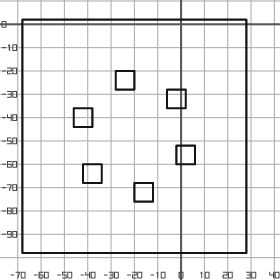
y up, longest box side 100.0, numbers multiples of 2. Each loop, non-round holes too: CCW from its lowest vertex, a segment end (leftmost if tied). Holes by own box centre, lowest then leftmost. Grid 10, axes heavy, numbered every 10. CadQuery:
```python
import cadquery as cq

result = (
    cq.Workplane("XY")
    .moveTo(-68.0, -98.0)
    .lineTo(28.0, -98.0)
    .lineTo(28.0, 2.0)
    .lineTo(-68.0, 2.0)
    .close()
    .moveTo(-20.0, -76.0)
    .lineTo(-12.0, -76.0)
    .lineTo(-12.0, -68.0)
    .lineTo(-20.0, -68.0)
    .close()
    .moveTo(-42.0, -68.0)
    .lineTo(-34.0, -68.0)
    .lineTo(-34.0, -60.0)
    .lineTo(-42.0, -60.0)
    .close()
    .moveTo(-2.0, -60.0)
    .lineTo(6.0, -60.0)
    .lineTo(6.0, -52.0)
    .lineTo(-2.0, -52.0)
    .close()
    .moveTo(-46.0, -44.0)
    .lineTo(-38.0, -44.0)
    .lineTo(-38.0, -36.0)
    .lineTo(-46.0, -36.0)
    .close()
    .moveTo(-6.0, -36.0)
    .lineTo(2.0, -36.0)
    .lineTo(2.0, -28.0)
    .lineTo(-6.0, -28.0)
    .close()
    .moveTo(-28.0, -28.0)
    .lineTo(-20.0, -28.0)
    .lineTo(-20.0, -20.0)
    .lineTo(-28.0, -20.0)
    .close()
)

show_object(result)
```